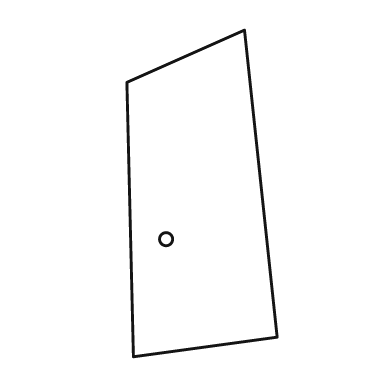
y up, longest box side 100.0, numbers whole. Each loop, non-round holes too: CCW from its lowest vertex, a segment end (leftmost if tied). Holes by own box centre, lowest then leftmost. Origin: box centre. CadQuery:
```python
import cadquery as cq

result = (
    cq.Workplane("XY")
    .moveTo(-21.0, -50.0)
    .lineTo(23.0, -44.0)
    .lineTo(13.0, 50.0)
    .lineTo(-23.0, 34.0)
    .close()
    .moveTo(-11.0, -14.0)
    .circle(2.0)
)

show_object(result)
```